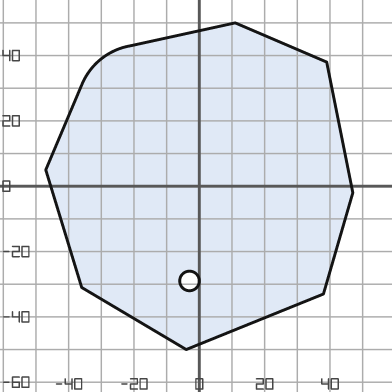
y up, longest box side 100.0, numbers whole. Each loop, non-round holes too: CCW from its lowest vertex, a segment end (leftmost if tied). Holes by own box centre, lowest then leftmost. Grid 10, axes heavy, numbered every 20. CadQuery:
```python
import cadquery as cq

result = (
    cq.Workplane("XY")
    .moveTo(-4.0, -50.0)
    .lineTo(38.0, -33.0)
    .lineTo(47.0, -2.0)
    .lineTo(39.0, 38.0)
    .lineTo(11.0, 50.0)
    .lineTo(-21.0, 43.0)
    .threePointArc((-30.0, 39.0), (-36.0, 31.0))
    .lineTo(-47.0, 5.0)
    .lineTo(-36.0, -31.0)
    .close()
    .moveTo(-3.0, -29.0)
    .circle(3.0)
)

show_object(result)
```